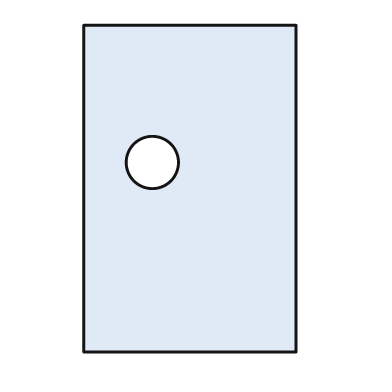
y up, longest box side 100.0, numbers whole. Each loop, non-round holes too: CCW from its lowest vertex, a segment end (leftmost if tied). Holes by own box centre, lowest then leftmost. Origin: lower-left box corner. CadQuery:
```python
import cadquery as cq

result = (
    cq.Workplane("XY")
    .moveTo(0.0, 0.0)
    .lineTo(65.0, 0.0)
    .lineTo(65.0, 100.0)
    .lineTo(0.0, 100.0)
    .close()
    .moveTo(21.0, 58.0)
    .circle(8.0)
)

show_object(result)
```